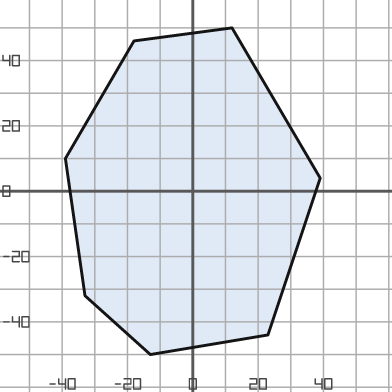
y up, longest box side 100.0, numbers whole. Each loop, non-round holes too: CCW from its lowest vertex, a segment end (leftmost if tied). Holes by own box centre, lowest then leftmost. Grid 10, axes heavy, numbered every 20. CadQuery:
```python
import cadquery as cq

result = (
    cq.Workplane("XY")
    .moveTo(-13.0, -50.0)
    .lineTo(23.0, -44.0)
    .lineTo(39.0, 4.0)
    .lineTo(12.0, 50.0)
    .lineTo(-18.0, 46.0)
    .lineTo(-39.0, 10.0)
    .lineTo(-33.0, -32.0)
    .close()
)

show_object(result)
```